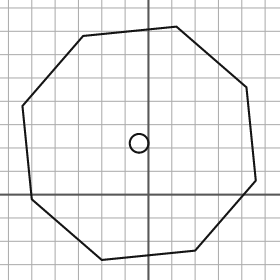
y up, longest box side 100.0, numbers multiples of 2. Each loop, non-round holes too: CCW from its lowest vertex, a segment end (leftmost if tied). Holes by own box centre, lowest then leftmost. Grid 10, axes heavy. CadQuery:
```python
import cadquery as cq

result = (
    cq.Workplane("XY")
    .moveTo(-20.0, -28.0)
    .lineTo(20.0, -24.0)
    .lineTo(46.0, 6.0)
    .lineTo(42.0, 46.0)
    .lineTo(12.0, 72.0)
    .lineTo(-28.0, 68.0)
    .lineTo(-54.0, 38.0)
    .lineTo(-50.0, -2.0)
    .close()
    .moveTo(-4.0, 22.0)
    .circle(4.0)
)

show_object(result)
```